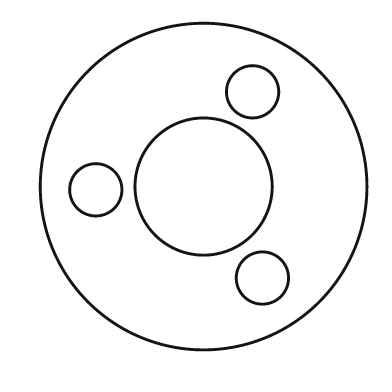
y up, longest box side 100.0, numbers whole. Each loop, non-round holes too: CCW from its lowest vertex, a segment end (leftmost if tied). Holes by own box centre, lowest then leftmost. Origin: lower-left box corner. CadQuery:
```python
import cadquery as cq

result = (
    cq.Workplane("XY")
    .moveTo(50.0, 50.0)
    .circle(50.0)
    .moveTo(68.0, 22.0)
    .circle(8.0)
    .moveTo(17.0, 49.0)
    .circle(8.0)
    .moveTo(50.0, 50.0)
    .circle(21.0)
    .moveTo(65.0, 79.0)
    .circle(8.0)
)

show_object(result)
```